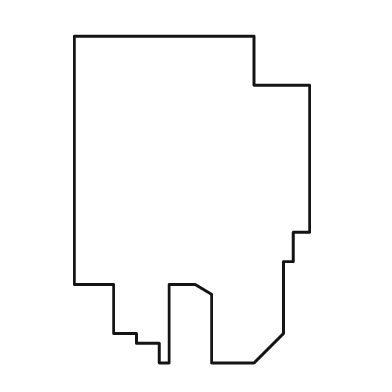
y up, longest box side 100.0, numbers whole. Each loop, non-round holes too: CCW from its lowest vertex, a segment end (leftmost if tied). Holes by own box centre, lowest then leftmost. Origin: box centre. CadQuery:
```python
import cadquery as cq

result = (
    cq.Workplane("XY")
    .moveTo(-10.0, -50.0)
    .lineTo(-7.0, -50.0)
    .lineTo(-7.0, -26.0)
    .lineTo(1.0, -26.0)
    .lineTo(6.0, -29.0)
    .lineTo(6.0, -50.0)
    .lineTo(19.0, -50.0)
    .lineTo(28.0, -41.0)
    .lineTo(28.0, -19.0)
    .lineTo(31.0, -19.0)
    .lineTo(31.0, -10.0)
    .lineTo(36.0, -10.0)
    .lineTo(36.0, 35.0)
    .lineTo(19.0, 35.0)
    .lineTo(19.0, 50.0)
    .lineTo(-36.0, 50.0)
    .lineTo(-36.0, -26.0)
    .lineTo(-24.0, -26.0)
    .lineTo(-24.0, -41.0)
    .lineTo(-17.0, -41.0)
    .lineTo(-17.0, -44.0)
    .lineTo(-10.0, -44.0)
    .close()
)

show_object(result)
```